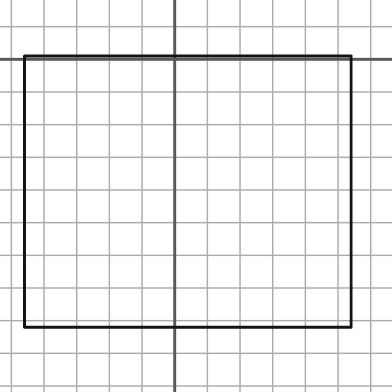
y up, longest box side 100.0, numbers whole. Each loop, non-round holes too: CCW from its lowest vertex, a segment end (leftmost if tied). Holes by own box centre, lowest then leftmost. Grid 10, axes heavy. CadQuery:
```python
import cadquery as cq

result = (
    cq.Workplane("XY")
    .moveTo(-46.0, -82.0)
    .lineTo(54.0, -82.0)
    .lineTo(54.0, 1.0)
    .lineTo(-46.0, 1.0)
    .close()
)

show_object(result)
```